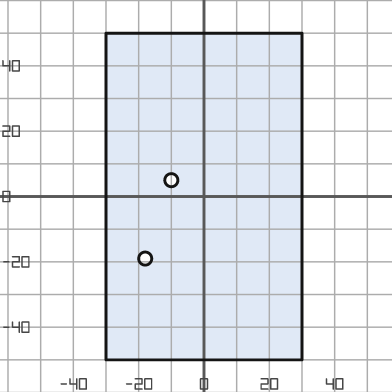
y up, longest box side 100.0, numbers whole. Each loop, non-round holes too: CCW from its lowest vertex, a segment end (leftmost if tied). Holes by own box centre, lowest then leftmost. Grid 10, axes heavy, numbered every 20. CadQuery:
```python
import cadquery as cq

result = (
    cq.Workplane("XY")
    .moveTo(-30.0, -50.0)
    .lineTo(30.0, -50.0)
    .lineTo(30.0, 50.0)
    .lineTo(-30.0, 50.0)
    .close()
    .moveTo(-18.0, -19.0)
    .circle(2.0)
    .moveTo(-10.0, 5.0)
    .circle(2.0)
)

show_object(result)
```